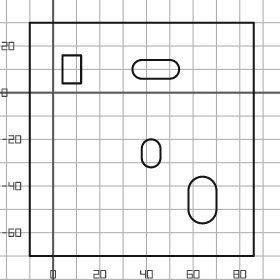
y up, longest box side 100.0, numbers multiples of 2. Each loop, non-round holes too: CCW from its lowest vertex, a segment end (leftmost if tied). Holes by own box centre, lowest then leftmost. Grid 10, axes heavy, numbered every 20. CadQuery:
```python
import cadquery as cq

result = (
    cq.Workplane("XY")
    .moveTo(-10.0, -70.0)
    .lineTo(86.0, -70.0)
    .lineTo(86.0, 30.0)
    .lineTo(-10.0, 30.0)
    .close()
    .moveTo(58.0, -50.0)
    .threePointArc((64.0, -56.0), (70.0, -50.0))
    .lineTo(70.0, -42.0)
    .threePointArc((64.0, -36.0), (58.0, -42.0))
    .close()
    .moveTo(38.0, -28.0)
    .threePointArc((42.0, -32.0), (46.0, -28.0))
    .lineTo(46.0, -24.0)
    .threePointArc((42.0, -20.0), (38.0, -24.0))
    .close()
    .moveTo(4.0, 4.0)
    .lineTo(12.0, 4.0)
    .lineTo(12.0, 16.0)
    .lineTo(4.0, 16.0)
    .close()
    .moveTo(38.0, 6.0)
    .lineTo(50.0, 6.0)
    .threePointArc((54.0, 10.0), (50.0, 14.0))
    .lineTo(38.0, 14.0)
    .threePointArc((34.0, 10.0), (38.0, 6.0))
    .close()
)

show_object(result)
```